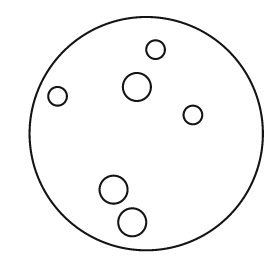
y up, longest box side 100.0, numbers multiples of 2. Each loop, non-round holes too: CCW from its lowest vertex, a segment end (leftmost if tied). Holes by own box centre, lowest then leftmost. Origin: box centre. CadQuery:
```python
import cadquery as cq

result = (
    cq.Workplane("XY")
    .moveTo(0.0, 0.0)
    .circle(50.0)
    .moveTo(-6.0, -38.0)
    .circle(6.0)
    .moveTo(-14.0, -24.0)
    .circle(6.0)
    .moveTo(20.0, 8.0)
    .circle(4.0)
    .moveTo(-38.0, 16.0)
    .circle(4.0)
    .moveTo(-4.0, 20.0)
    .circle(6.0)
    .moveTo(4.0, 36.0)
    .circle(4.0)
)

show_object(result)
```